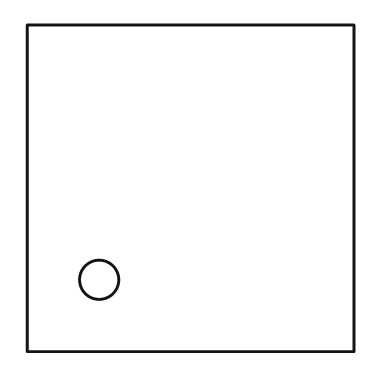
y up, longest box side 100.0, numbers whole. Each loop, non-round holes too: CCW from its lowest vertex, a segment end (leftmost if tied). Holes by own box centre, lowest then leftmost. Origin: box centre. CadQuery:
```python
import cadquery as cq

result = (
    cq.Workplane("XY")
    .moveTo(-50.0, -50.0)
    .lineTo(50.0, -50.0)
    .lineTo(50.0, 50.0)
    .lineTo(-50.0, 50.0)
    .close()
    .moveTo(-28.0, -28.0)
    .circle(6.0)
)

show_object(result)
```